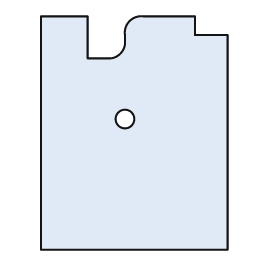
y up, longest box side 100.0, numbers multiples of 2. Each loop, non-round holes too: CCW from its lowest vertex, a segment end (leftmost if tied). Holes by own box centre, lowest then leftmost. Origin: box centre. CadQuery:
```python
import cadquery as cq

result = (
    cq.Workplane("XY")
    .moveTo(-40.0, -50.0)
    .lineTo(40.0, -50.0)
    .lineTo(40.0, 42.0)
    .lineTo(26.0, 42.0)
    .lineTo(26.0, 50.0)
    .lineTo(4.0, 50.0)
    .threePointArc((-2.0, 48.0), (-4.0, 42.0))
    .lineTo(-4.0, 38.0)
    .threePointArc((-6.0, 34.0), (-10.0, 32.0))
    .lineTo(-20.0, 32.0)
    .lineTo(-20.0, 50.0)
    .lineTo(-40.0, 50.0)
    .close()
    .moveTo(-4.0, 6.0)
    .circle(4.0)
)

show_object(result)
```